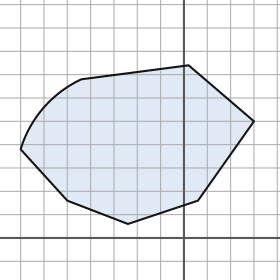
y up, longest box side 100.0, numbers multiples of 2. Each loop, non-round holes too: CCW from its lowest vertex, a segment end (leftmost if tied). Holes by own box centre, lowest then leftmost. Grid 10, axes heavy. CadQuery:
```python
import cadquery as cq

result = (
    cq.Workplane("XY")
    .moveTo(-24.0, 6.0)
    .lineTo(6.0, 16.0)
    .lineTo(30.0, 50.0)
    .lineTo(2.0, 74.0)
    .lineTo(-44.0, 68.0)
    .threePointArc((-60.0, 56.0), (-70.0, 38.0))
    .lineTo(-50.0, 16.0)
    .close()
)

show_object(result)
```